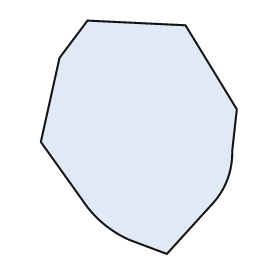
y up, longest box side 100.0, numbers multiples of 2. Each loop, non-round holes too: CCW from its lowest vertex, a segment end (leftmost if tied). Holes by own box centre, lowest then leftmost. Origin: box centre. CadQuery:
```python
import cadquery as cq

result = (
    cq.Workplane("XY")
    .moveTo(12.0, -50.0)
    .lineTo(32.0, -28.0)
    .threePointArc((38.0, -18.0), (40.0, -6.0))
    .lineTo(42.0, 12.0)
    .lineTo(20.0, 48.0)
    .lineTo(-22.0, 50.0)
    .lineTo(-34.0, 34.0)
    .lineTo(-42.0, -2.0)
    .lineTo(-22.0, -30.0)
    .threePointArc((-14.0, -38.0), (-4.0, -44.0))
    .close()
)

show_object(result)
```